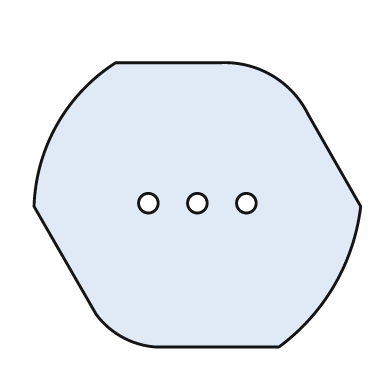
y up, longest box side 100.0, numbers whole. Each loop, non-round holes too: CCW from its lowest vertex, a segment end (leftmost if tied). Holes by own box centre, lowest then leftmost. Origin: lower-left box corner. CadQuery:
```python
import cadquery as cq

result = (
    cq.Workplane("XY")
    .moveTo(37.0, 0.0)
    .lineTo(75.0, 0.0)
    .threePointArc((92.0, 19.0), (100.0, 43.0))
    .lineTo(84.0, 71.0)
    .threePointArc((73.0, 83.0), (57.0, 87.0))
    .lineTo(25.0, 87.0)
    .threePointArc((7.0, 68.0), (0.0, 43.0))
    .lineTo(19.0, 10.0)
    .threePointArc((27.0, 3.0), (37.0, 0.0))
    .close()
    .moveTo(35.0, 44.0)
    .circle(3.0)
    .moveTo(50.0, 44.0)
    .circle(3.0)
    .moveTo(65.0, 44.0)
    .circle(3.0)
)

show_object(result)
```